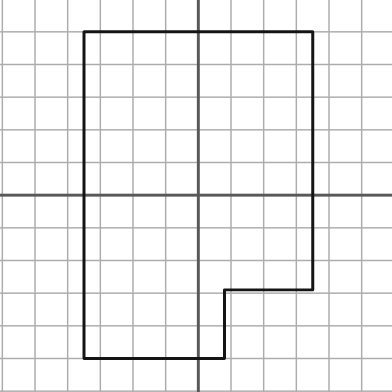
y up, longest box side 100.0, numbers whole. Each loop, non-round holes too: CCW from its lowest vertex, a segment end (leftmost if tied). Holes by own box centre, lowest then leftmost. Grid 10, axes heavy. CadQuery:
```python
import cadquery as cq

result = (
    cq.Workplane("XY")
    .moveTo(-35.0, -50.0)
    .lineTo(8.0, -50.0)
    .lineTo(8.0, -29.0)
    .lineTo(35.0, -29.0)
    .lineTo(35.0, 50.0)
    .lineTo(-35.0, 50.0)
    .close()
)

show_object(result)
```